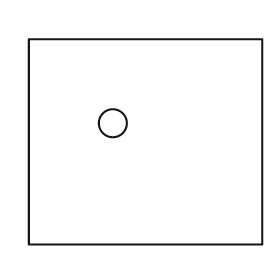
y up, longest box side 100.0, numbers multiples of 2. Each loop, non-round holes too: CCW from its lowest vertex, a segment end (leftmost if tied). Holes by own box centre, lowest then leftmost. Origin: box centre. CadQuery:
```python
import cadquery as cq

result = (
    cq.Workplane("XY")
    .moveTo(-50.0, -44.0)
    .lineTo(50.0, -44.0)
    .lineTo(50.0, 44.0)
    .lineTo(-50.0, 44.0)
    .close()
    .moveTo(-14.0, 8.0)
    .circle(6.0)
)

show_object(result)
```